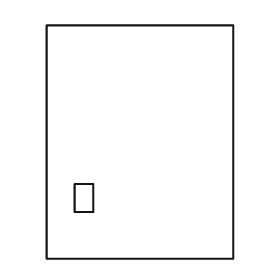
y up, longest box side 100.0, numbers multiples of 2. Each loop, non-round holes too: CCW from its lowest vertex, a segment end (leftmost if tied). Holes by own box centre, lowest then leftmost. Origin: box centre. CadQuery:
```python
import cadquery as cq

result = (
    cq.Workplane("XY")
    .moveTo(-40.0, -50.0)
    .lineTo(40.0, -50.0)
    .lineTo(40.0, 50.0)
    .lineTo(-40.0, 50.0)
    .close()
    .moveTo(-28.0, -30.0)
    .lineTo(-20.0, -30.0)
    .lineTo(-20.0, -18.0)
    .lineTo(-28.0, -18.0)
    .close()
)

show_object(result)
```